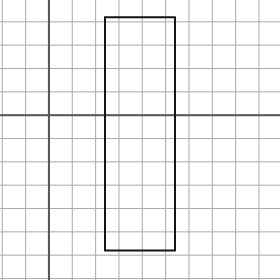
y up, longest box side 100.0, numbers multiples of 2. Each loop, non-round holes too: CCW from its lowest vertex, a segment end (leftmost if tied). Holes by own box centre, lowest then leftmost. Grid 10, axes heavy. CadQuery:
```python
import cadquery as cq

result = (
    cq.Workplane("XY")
    .moveTo(24.0, -58.0)
    .lineTo(54.0, -58.0)
    .lineTo(54.0, 42.0)
    .lineTo(24.0, 42.0)
    .close()
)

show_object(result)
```